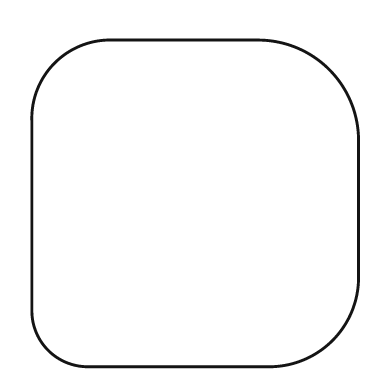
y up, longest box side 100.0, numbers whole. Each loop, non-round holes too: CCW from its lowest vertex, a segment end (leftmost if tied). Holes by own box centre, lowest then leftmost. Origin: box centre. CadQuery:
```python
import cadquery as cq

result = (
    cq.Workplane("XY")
    .moveTo(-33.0, -50.0)
    .lineTo(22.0, -50.0)
    .threePointArc((42.0, -42.0), (50.0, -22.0))
    .lineTo(50.0, 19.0)
    .threePointArc((41.0, 41.0), (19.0, 50.0))
    .lineTo(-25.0, 50.0)
    .threePointArc((-43.0, 43.0), (-50.0, 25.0))
    .lineTo(-50.0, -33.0)
    .threePointArc((-45.0, -45.0), (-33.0, -50.0))
    .close()
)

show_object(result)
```